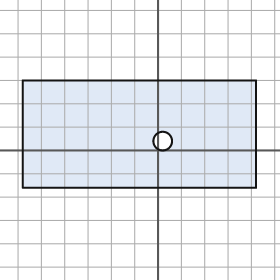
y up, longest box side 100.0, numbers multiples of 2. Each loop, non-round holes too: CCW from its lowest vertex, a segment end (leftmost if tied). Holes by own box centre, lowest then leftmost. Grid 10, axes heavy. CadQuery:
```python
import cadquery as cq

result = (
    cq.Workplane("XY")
    .moveTo(-58.0, -16.0)
    .lineTo(42.0, -16.0)
    .lineTo(42.0, 30.0)
    .lineTo(-58.0, 30.0)
    .close()
    .moveTo(2.0, 4.0)
    .circle(4.0)
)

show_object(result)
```